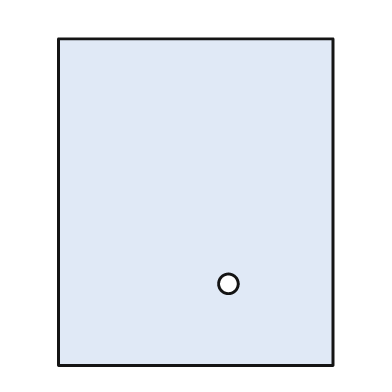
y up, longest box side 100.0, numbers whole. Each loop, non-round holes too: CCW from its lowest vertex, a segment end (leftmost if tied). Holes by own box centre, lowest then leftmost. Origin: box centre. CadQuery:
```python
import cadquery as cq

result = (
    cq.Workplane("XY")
    .moveTo(-42.0, -50.0)
    .lineTo(42.0, -50.0)
    .lineTo(42.0, 50.0)
    .lineTo(-42.0, 50.0)
    .close()
    .moveTo(10.0, -25.0)
    .circle(3.0)
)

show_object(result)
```